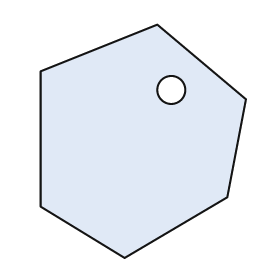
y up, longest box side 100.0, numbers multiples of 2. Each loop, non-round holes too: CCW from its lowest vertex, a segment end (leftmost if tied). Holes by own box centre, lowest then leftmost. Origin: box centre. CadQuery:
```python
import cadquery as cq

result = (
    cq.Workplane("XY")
    .moveTo(-8.0, -50.0)
    .lineTo(36.0, -24.0)
    .lineTo(44.0, 18.0)
    .lineTo(6.0, 50.0)
    .lineTo(-44.0, 30.0)
    .lineTo(-44.0, -28.0)
    .close()
    .moveTo(12.0, 22.0)
    .circle(6.0)
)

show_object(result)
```